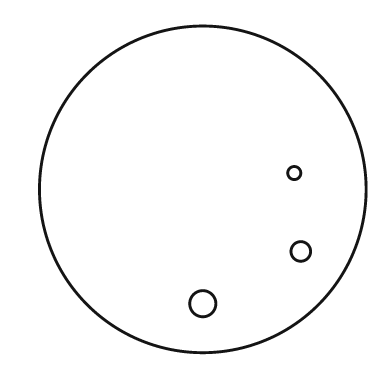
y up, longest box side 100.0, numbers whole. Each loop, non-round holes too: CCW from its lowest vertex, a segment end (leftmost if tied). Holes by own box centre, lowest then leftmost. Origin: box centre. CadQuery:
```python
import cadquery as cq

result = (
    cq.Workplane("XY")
    .moveTo(0.0, 0.0)
    .circle(50.0)
    .moveTo(0.0, -35.0)
    .circle(4.0)
    .moveTo(30.0, -19.0)
    .circle(3.0)
    .moveTo(28.0, 5.0)
    .circle(2.0)
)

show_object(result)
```